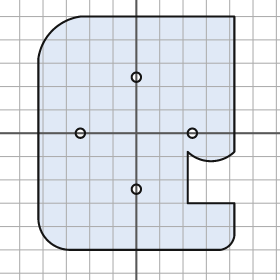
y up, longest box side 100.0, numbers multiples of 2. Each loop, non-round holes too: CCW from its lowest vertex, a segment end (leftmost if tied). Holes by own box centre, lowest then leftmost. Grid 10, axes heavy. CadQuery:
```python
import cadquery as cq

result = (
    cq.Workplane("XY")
    .moveTo(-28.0, -50.0)
    .lineTo(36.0, -50.0)
    .threePointArc((40.0, -48.0), (42.0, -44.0))
    .lineTo(42.0, -30.0)
    .lineTo(22.0, -30.0)
    .lineTo(22.0, -8.0)
    .threePointArc((32.0, -12.0), (42.0, -8.0))
    .lineTo(42.0, 50.0)
    .lineTo(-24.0, 50.0)
    .threePointArc((-36.0, 44.0), (-42.0, 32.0))
    .lineTo(-42.0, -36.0)
    .threePointArc((-38.0, -46.0), (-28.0, -50.0))
    .close()
    .moveTo(0.0, -24.0)
    .circle(2.0)
    .moveTo(-24.0, 0.0)
    .circle(2.0)
    .moveTo(24.0, 0.0)
    .circle(2.0)
    .moveTo(0.0, 24.0)
    .circle(2.0)
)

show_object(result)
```